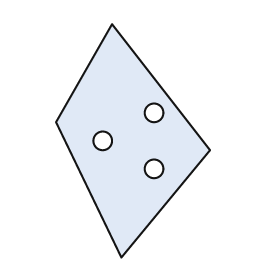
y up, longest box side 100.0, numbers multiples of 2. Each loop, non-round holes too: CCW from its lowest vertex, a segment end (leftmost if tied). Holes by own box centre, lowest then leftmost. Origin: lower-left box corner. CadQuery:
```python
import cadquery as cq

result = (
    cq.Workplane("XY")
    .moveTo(28.0, 0.0)
    .lineTo(66.0, 46.0)
    .lineTo(24.0, 100.0)
    .lineTo(0.0, 58.0)
    .close()
    .moveTo(42.0, 38.0)
    .circle(4.0)
    .moveTo(20.0, 50.0)
    .circle(4.0)
    .moveTo(42.0, 62.0)
    .circle(4.0)
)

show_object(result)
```